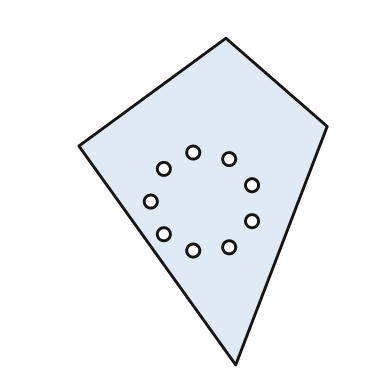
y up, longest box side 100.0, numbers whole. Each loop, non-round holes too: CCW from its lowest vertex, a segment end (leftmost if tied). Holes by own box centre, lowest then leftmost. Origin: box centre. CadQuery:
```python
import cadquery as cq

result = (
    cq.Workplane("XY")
    .moveTo(10.0, -50.0)
    .lineTo(38.0, 23.0)
    .lineTo(7.0, 50.0)
    .lineTo(-38.0, 17.0)
    .close()
    .moveTo(-3.0, -15.0)
    .circle(2.0)
    .moveTo(8.0, -14.0)
    .circle(2.0)
    .moveTo(-12.0, -10.0)
    .circle(2.0)
    .moveTo(15.0, -6.0)
    .circle(2.0)
    .moveTo(-16.0, 0.0)
    .circle(2.0)
    .moveTo(15.0, 5.0)
    .circle(2.0)
    .moveTo(-12.0, 10.0)
    .circle(2.0)
    .moveTo(8.0, 13.0)
    .circle(2.0)
    .moveTo(-3.0, 15.0)
    .circle(2.0)
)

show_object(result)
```